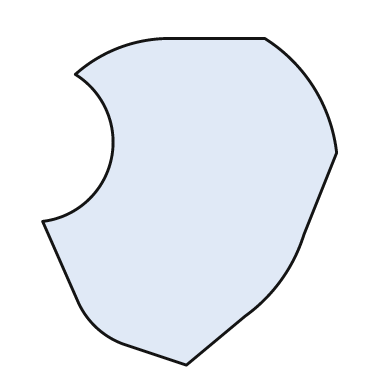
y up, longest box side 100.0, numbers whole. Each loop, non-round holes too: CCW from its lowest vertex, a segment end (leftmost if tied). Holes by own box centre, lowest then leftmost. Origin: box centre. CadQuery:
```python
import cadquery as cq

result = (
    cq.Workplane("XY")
    .moveTo(-1.0, -50.0)
    .lineTo(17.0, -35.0)
    .threePointArc((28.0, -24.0), (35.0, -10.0))
    .lineTo(45.0, 15.0)
    .threePointArc((38.0, 35.0), (23.0, 50.0))
    .lineTo(-7.0, 50.0)
    .threePointArc((-22.0, 47.0), (-35.0, 39.0))
    .threePointArc((-24.0, 13.0), (-45.0, -6.0))
    .lineTo(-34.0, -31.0)
    .threePointArc((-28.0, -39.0), (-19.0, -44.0))
    .close()
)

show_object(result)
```